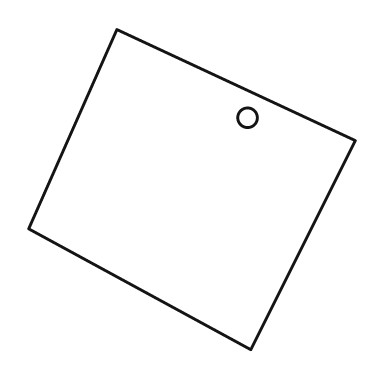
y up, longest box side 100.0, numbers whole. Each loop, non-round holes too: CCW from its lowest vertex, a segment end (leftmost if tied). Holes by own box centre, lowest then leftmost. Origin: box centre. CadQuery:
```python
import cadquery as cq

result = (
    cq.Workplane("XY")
    .moveTo(18.0, -49.0)
    .lineTo(50.0, 15.0)
    .lineTo(-23.0, 49.0)
    .lineTo(-50.0, -12.0)
    .close()
    .moveTo(17.0, 22.0)
    .circle(3.0)
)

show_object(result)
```